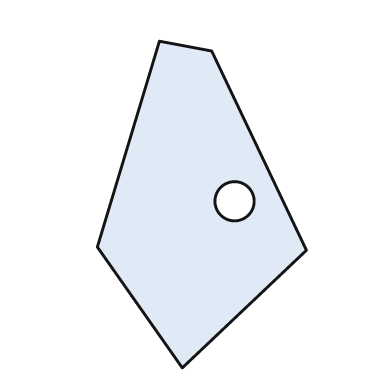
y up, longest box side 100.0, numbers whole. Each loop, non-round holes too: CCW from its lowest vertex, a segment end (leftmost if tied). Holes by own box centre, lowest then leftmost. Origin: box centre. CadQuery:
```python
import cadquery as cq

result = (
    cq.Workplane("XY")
    .moveTo(-6.0, -50.0)
    .lineTo(32.0, -14.0)
    .lineTo(3.0, 47.0)
    .lineTo(-13.0, 50.0)
    .lineTo(-32.0, -13.0)
    .close()
    .moveTo(10.0, 1.0)
    .circle(6.0)
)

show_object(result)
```